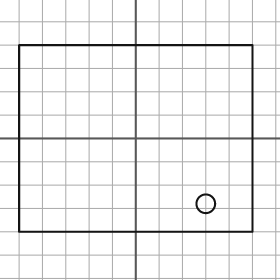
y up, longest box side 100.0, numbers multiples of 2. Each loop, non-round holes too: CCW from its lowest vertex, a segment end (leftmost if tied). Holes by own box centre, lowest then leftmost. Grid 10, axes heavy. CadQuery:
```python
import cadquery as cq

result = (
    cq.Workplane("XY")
    .moveTo(-50.0, -40.0)
    .lineTo(50.0, -40.0)
    .lineTo(50.0, 40.0)
    .lineTo(-50.0, 40.0)
    .close()
    .moveTo(30.0, -28.0)
    .circle(4.0)
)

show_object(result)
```